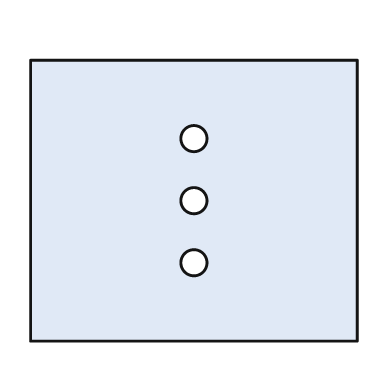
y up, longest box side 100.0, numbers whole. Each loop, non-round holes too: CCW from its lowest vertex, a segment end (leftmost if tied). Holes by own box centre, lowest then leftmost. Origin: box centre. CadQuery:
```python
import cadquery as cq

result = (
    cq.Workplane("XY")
    .moveTo(-50.0, -43.0)
    .lineTo(50.0, -43.0)
    .lineTo(50.0, 43.0)
    .lineTo(-50.0, 43.0)
    .close()
    .moveTo(0.0, -19.0)
    .circle(4.0)
    .moveTo(0.0, 0.0)
    .circle(4.0)
    .moveTo(0.0, 19.0)
    .circle(4.0)
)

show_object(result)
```